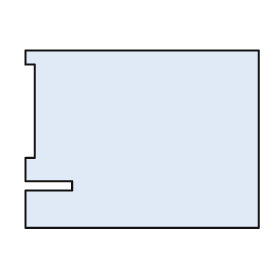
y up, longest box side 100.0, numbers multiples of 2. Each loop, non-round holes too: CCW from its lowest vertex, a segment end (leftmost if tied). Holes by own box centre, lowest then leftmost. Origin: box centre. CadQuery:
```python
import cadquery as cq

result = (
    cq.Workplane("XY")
    .moveTo(-50.0, -38.0)
    .lineTo(50.0, -38.0)
    .lineTo(50.0, 38.0)
    .lineTo(-50.0, 38.0)
    .lineTo(-50.0, 32.0)
    .lineTo(-46.0, 32.0)
    .lineTo(-46.0, -8.0)
    .lineTo(-50.0, -8.0)
    .lineTo(-50.0, -18.0)
    .lineTo(-30.0, -18.0)
    .lineTo(-30.0, -22.0)
    .lineTo(-50.0, -22.0)
    .close()
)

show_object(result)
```